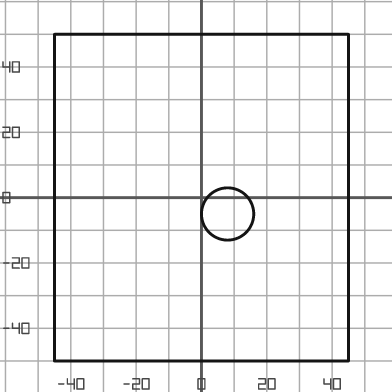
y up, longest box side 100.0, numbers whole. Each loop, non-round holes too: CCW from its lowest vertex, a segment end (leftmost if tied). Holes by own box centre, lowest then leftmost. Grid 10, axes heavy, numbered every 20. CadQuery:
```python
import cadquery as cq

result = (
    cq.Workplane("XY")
    .moveTo(-45.0, -50.0)
    .lineTo(45.0, -50.0)
    .lineTo(45.0, 50.0)
    .lineTo(-45.0, 50.0)
    .close()
    .moveTo(8.0, -5.0)
    .circle(8.0)
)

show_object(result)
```